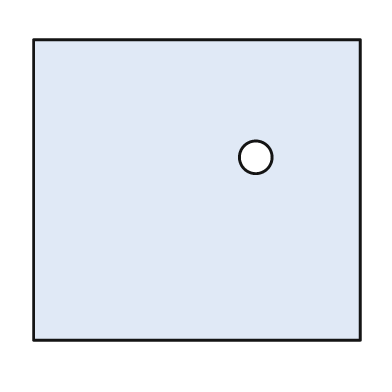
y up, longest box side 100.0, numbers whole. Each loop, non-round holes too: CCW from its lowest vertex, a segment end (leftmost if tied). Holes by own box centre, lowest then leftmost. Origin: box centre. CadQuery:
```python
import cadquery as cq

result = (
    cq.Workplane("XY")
    .moveTo(-50.0, -46.0)
    .lineTo(50.0, -46.0)
    .lineTo(50.0, 46.0)
    .lineTo(-50.0, 46.0)
    .close()
    .moveTo(18.0, 10.0)
    .circle(5.0)
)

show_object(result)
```